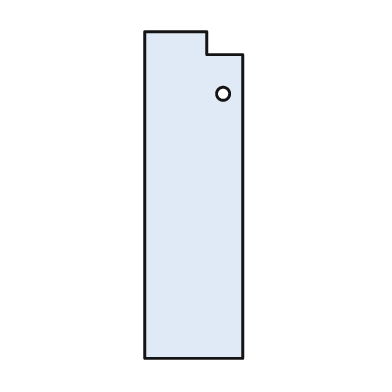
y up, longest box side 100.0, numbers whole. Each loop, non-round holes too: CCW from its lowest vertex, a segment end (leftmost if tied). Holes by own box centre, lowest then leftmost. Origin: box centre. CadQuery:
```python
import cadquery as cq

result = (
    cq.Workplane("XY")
    .moveTo(-15.0, -50.0)
    .lineTo(15.0, -50.0)
    .lineTo(15.0, 43.0)
    .lineTo(4.0, 43.0)
    .lineTo(4.0, 50.0)
    .lineTo(-15.0, 50.0)
    .close()
    .moveTo(9.0, 31.0)
    .circle(2.0)
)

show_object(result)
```